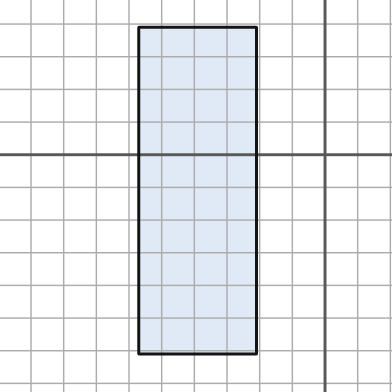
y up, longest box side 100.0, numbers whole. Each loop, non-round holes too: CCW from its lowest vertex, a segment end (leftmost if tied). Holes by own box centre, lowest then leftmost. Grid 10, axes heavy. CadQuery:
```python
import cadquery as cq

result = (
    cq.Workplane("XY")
    .moveTo(-57.0, -61.0)
    .lineTo(-21.0, -61.0)
    .lineTo(-21.0, 39.0)
    .lineTo(-57.0, 39.0)
    .close()
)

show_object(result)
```